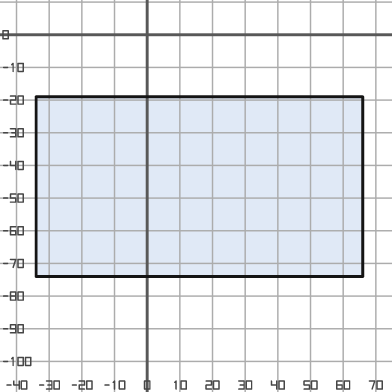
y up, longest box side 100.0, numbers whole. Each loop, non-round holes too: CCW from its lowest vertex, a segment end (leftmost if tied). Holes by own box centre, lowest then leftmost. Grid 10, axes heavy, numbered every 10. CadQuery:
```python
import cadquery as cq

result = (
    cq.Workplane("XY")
    .moveTo(-34.0, -74.0)
    .lineTo(66.0, -74.0)
    .lineTo(66.0, -19.0)
    .lineTo(-34.0, -19.0)
    .close()
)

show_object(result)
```